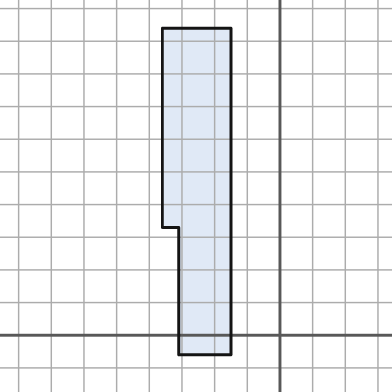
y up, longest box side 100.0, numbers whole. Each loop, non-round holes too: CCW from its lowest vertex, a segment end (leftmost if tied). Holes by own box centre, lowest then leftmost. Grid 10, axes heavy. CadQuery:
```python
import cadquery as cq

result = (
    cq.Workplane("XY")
    .moveTo(-31.0, -6.0)
    .lineTo(-15.0, -6.0)
    .lineTo(-15.0, 94.0)
    .lineTo(-36.0, 94.0)
    .lineTo(-36.0, 33.0)
    .lineTo(-31.0, 33.0)
    .close()
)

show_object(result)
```